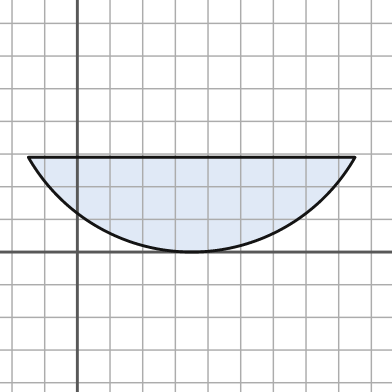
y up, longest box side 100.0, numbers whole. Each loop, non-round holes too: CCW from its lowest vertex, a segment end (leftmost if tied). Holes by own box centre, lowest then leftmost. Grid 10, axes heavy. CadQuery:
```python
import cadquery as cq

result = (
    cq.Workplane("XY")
    .moveTo(-15.0, 29.0)
    .threePointArc((35.0, 0.0), (85.0, 29.0))
    .close()
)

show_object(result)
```